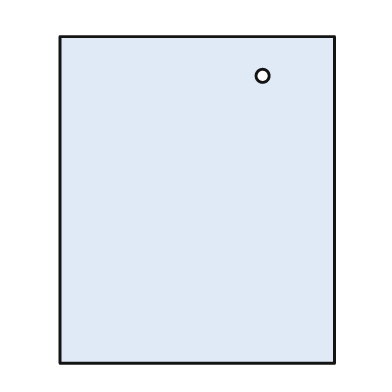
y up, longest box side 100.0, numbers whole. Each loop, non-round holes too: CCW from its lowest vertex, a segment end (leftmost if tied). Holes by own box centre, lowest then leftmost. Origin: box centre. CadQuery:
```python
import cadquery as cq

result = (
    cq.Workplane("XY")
    .moveTo(-42.0, -50.0)
    .lineTo(42.0, -50.0)
    .lineTo(42.0, 50.0)
    .lineTo(-42.0, 50.0)
    .close()
    .moveTo(20.0, 38.0)
    .circle(2.0)
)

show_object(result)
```